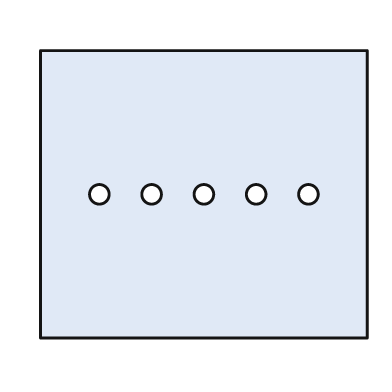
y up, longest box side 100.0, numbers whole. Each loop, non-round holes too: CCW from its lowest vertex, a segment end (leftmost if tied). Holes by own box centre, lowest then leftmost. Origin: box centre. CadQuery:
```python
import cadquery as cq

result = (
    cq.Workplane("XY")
    .moveTo(-50.0, -44.0)
    .lineTo(50.0, -44.0)
    .lineTo(50.0, 44.0)
    .lineTo(-50.0, 44.0)
    .close()
    .moveTo(-32.0, 0.0)
    .circle(3.0)
    .moveTo(-16.0, 0.0)
    .circle(3.0)
    .moveTo(0.0, 0.0)
    .circle(3.0)
    .moveTo(16.0, 0.0)
    .circle(3.0)
    .moveTo(32.0, 0.0)
    .circle(3.0)
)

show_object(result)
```